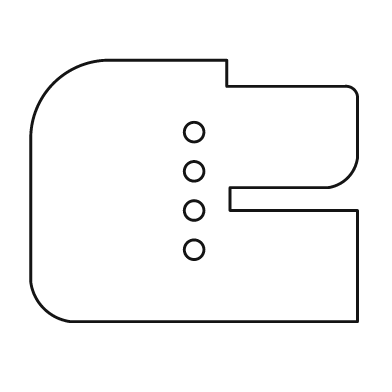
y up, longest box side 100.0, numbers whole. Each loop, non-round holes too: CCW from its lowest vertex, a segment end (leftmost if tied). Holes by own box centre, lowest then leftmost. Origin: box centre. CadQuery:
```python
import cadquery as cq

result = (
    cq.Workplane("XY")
    .moveTo(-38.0, -40.0)
    .lineTo(50.0, -40.0)
    .lineTo(50.0, -6.0)
    .lineTo(11.0, -6.0)
    .lineTo(11.0, 1.0)
    .lineTo(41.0, 1.0)
    .threePointArc((47.0, 4.0), (50.0, 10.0))
    .lineTo(50.0, 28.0)
    .threePointArc((49.0, 31.0), (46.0, 32.0))
    .lineTo(10.0, 32.0)
    .lineTo(10.0, 40.0)
    .lineTo(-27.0, 40.0)
    .threePointArc((-43.0, 33.0), (-50.0, 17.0))
    .lineTo(-50.0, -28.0)
    .threePointArc((-46.0, -36.0), (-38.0, -40.0))
    .close()
    .moveTo(0.0, -18.0)
    .circle(3.0)
    .moveTo(0.0, -6.0)
    .circle(3.0)
    .moveTo(0.0, 6.0)
    .circle(3.0)
    .moveTo(0.0, 18.0)
    .circle(3.0)
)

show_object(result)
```